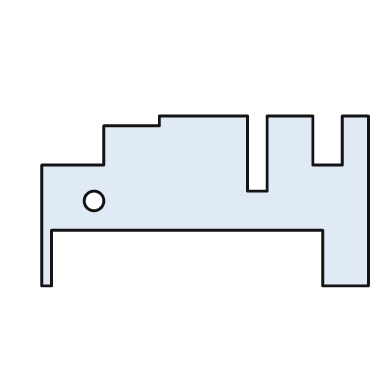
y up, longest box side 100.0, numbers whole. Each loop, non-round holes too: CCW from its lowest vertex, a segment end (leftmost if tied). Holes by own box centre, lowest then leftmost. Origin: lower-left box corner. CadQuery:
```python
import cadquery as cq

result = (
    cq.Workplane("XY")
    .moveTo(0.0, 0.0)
    .lineTo(3.0, 0.0)
    .lineTo(3.0, 17.0)
    .lineTo(86.0, 17.0)
    .lineTo(86.0, 0.0)
    .lineTo(100.0, 0.0)
    .lineTo(100.0, 52.0)
    .lineTo(92.0, 52.0)
    .lineTo(92.0, 37.0)
    .lineTo(83.0, 37.0)
    .lineTo(83.0, 52.0)
    .lineTo(69.0, 52.0)
    .lineTo(69.0, 29.0)
    .lineTo(63.0, 29.0)
    .lineTo(63.0, 52.0)
    .lineTo(36.0, 52.0)
    .lineTo(36.0, 49.0)
    .lineTo(19.0, 49.0)
    .lineTo(19.0, 37.0)
    .lineTo(0.0, 37.0)
    .close()
    .moveTo(16.0, 26.0)
    .circle(3.0)
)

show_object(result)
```